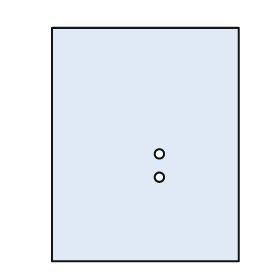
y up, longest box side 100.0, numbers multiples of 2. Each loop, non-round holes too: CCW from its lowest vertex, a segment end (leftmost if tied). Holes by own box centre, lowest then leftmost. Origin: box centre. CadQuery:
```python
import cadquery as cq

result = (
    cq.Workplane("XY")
    .moveTo(-40.0, -50.0)
    .lineTo(40.0, -50.0)
    .lineTo(40.0, 50.0)
    .lineTo(-40.0, 50.0)
    .close()
    .moveTo(6.0, -14.0)
    .circle(2.0)
    .moveTo(6.0, -4.0)
    .circle(2.0)
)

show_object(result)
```